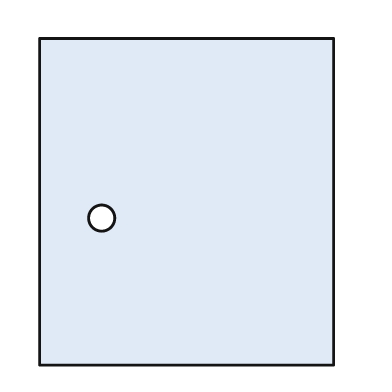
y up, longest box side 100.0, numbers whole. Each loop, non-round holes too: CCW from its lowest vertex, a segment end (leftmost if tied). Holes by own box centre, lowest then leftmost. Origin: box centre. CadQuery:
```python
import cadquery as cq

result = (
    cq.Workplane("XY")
    .moveTo(-45.0, -50.0)
    .lineTo(45.0, -50.0)
    .lineTo(45.0, 50.0)
    .lineTo(-45.0, 50.0)
    .close()
    .moveTo(-26.0, -5.0)
    .circle(4.0)
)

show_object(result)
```